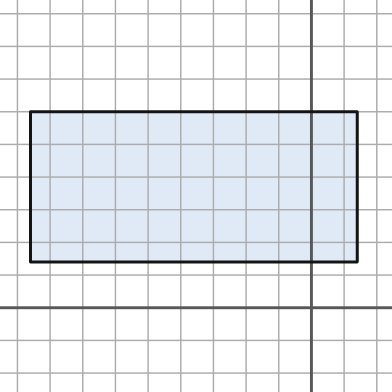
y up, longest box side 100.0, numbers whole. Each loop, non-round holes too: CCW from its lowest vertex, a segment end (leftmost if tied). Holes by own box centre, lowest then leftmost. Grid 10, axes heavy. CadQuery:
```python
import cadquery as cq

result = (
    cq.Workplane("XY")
    .moveTo(-86.0, 14.0)
    .lineTo(14.0, 14.0)
    .lineTo(14.0, 60.0)
    .lineTo(-86.0, 60.0)
    .close()
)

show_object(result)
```